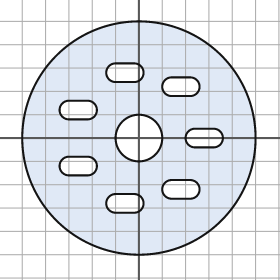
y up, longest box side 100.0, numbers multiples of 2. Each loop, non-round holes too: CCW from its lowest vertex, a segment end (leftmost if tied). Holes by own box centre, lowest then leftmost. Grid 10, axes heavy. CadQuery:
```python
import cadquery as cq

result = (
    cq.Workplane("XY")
    .moveTo(0.0, 0.0)
    .circle(50.0)
    .moveTo(-10.0, -32.0)
    .lineTo(-2.0, -32.0)
    .threePointArc((2.0, -28.0), (-2.0, -24.0))
    .lineTo(-10.0, -24.0)
    .threePointArc((-14.0, -28.0), (-10.0, -32.0))
    .close()
    .moveTo(14.0, -26.0)
    .lineTo(22.0, -26.0)
    .threePointArc((26.0, -22.0), (22.0, -18.0))
    .lineTo(14.0, -18.0)
    .threePointArc((10.0, -22.0), (14.0, -26.0))
    .close()
    .moveTo(-30.0, -16.0)
    .lineTo(-22.0, -16.0)
    .threePointArc((-18.0, -12.0), (-22.0, -8.0))
    .lineTo(-30.0, -8.0)
    .threePointArc((-34.0, -12.0), (-30.0, -16.0))
    .close()
    .moveTo(0.0, 0.0)
    .circle(10.0)
    .moveTo(24.0, -4.0)
    .lineTo(32.0, -4.0)
    .threePointArc((36.0, 0.0), (32.0, 4.0))
    .lineTo(24.0, 4.0)
    .threePointArc((20.0, 0.0), (24.0, -4.0))
    .close()
    .moveTo(-30.0, 8.0)
    .lineTo(-22.0, 8.0)
    .threePointArc((-18.0, 12.0), (-22.0, 16.0))
    .lineTo(-30.0, 16.0)
    .threePointArc((-34.0, 12.0), (-30.0, 8.0))
    .close()
    .moveTo(14.0, 18.0)
    .lineTo(22.0, 18.0)
    .threePointArc((26.0, 22.0), (22.0, 26.0))
    .lineTo(14.0, 26.0)
    .threePointArc((10.0, 22.0), (14.0, 18.0))
    .close()
    .moveTo(-10.0, 24.0)
    .lineTo(-2.0, 24.0)
    .threePointArc((2.0, 28.0), (-2.0, 32.0))
    .lineTo(-10.0, 32.0)
    .threePointArc((-14.0, 28.0), (-10.0, 24.0))
    .close()
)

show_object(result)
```